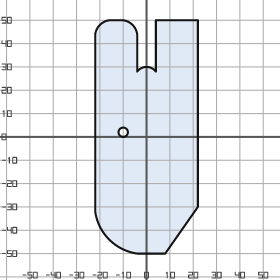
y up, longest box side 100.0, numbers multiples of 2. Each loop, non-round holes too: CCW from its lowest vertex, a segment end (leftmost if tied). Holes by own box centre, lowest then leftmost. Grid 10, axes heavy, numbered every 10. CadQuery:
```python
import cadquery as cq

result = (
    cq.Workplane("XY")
    .moveTo(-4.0, -50.0)
    .lineTo(8.0, -50.0)
    .lineTo(22.0, -30.0)
    .lineTo(22.0, 50.0)
    .lineTo(4.0, 50.0)
    .lineTo(4.0, 28.0)
    .threePointArc((0.0, 30.0), (-4.0, 28.0))
    .lineTo(-4.0, 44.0)
    .threePointArc((-6.0, 48.0), (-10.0, 50.0))
    .lineTo(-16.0, 50.0)
    .threePointArc((-20.0, 48.0), (-22.0, 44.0))
    .lineTo(-22.0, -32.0)
    .threePointArc((-16.0, -44.0), (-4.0, -50.0))
    .close()
    .moveTo(-10.0, 2.0)
    .circle(2.0)
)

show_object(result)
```